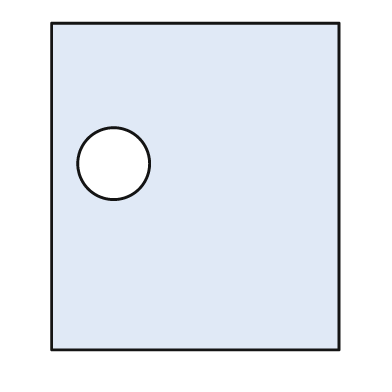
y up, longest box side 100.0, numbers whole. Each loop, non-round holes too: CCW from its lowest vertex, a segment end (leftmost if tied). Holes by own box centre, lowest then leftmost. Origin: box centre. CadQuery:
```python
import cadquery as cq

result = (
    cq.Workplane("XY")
    .moveTo(-44.0, -50.0)
    .lineTo(44.0, -50.0)
    .lineTo(44.0, 50.0)
    .lineTo(-44.0, 50.0)
    .close()
    .moveTo(-25.0, 7.0)
    .circle(11.0)
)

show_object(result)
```